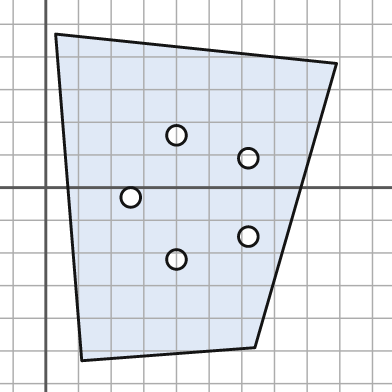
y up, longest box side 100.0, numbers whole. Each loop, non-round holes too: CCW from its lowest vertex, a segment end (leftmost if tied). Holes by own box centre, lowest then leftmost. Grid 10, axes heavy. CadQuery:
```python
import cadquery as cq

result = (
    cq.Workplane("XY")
    .moveTo(11.0, -53.0)
    .lineTo(64.0, -49.0)
    .lineTo(89.0, 38.0)
    .lineTo(3.0, 47.0)
    .close()
    .moveTo(40.0, -22.0)
    .circle(3.0)
    .moveTo(62.0, -15.0)
    .circle(3.0)
    .moveTo(26.0, -3.0)
    .circle(3.0)
    .moveTo(62.0, 9.0)
    .circle(3.0)
    .moveTo(40.0, 16.0)
    .circle(3.0)
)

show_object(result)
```